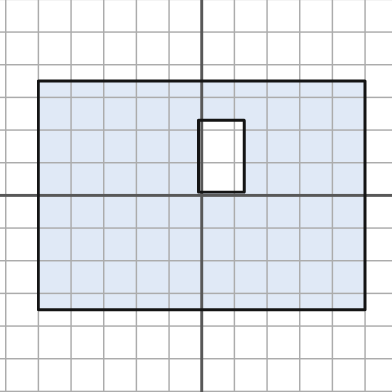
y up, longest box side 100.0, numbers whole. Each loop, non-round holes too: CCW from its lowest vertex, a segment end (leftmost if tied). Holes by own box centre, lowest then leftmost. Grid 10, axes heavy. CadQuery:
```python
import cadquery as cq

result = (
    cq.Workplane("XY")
    .moveTo(-50.0, -35.0)
    .lineTo(50.0, -35.0)
    .lineTo(50.0, 35.0)
    .lineTo(-50.0, 35.0)
    .close()
    .moveTo(-1.0, 1.0)
    .lineTo(13.0, 1.0)
    .lineTo(13.0, 23.0)
    .lineTo(-1.0, 23.0)
    .close()
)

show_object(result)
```